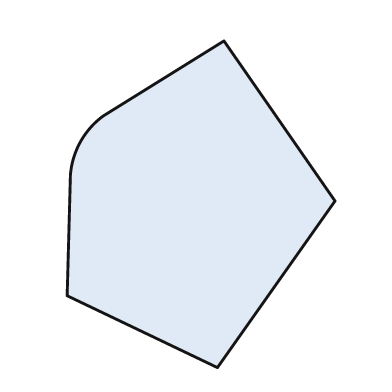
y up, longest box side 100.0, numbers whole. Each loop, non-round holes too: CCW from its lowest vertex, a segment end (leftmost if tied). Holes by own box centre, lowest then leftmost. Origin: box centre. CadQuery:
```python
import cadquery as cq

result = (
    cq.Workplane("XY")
    .moveTo(5.0, -50.0)
    .lineTo(41.0, 1.0)
    .lineTo(7.0, 50.0)
    .lineTo(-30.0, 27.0)
    .threePointArc((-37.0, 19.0), (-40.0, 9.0))
    .lineTo(-41.0, -28.0)
    .close()
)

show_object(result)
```